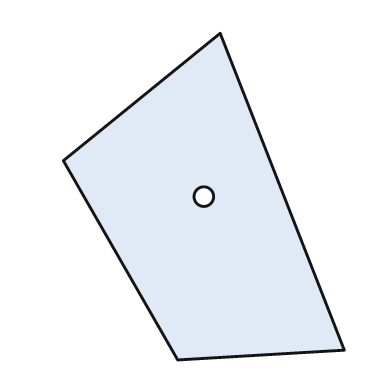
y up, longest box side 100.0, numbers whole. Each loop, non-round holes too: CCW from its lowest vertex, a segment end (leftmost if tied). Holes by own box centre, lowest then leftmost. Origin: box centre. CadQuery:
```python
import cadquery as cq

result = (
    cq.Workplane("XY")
    .moveTo(-8.0, -50.0)
    .lineTo(43.0, -47.0)
    .lineTo(5.0, 50.0)
    .lineTo(-43.0, 11.0)
    .close()
    .moveTo(0.0, 0.0)
    .circle(3.0)
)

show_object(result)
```